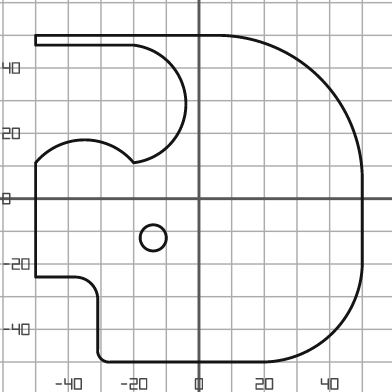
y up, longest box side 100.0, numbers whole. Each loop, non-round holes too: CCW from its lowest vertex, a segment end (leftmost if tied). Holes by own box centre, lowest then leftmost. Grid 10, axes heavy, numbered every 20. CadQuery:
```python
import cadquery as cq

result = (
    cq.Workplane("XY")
    .moveTo(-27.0, -50.0)
    .lineTo(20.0, -50.0)
    .threePointArc((41.0, -41.0), (50.0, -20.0))
    .lineTo(50.0, 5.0)
    .threePointArc((37.0, 37.0), (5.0, 50.0))
    .lineTo(-50.0, 50.0)
    .lineTo(-50.0, 47.0)
    .lineTo(-20.0, 47.0)
    .threePointArc((-4.0, 29.0), (-20.0, 11.0))
    .threePointArc((-35.0, 18.0), (-50.0, 11.0))
    .lineTo(-50.0, -24.0)
    .lineTo(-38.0, -24.0)
    .threePointArc((-33.0, -26.0), (-31.0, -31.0))
    .lineTo(-31.0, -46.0)
    .threePointArc((-30.0, -49.0), (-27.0, -50.0))
    .close()
    .moveTo(-14.0, -12.0)
    .circle(4.0)
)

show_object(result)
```